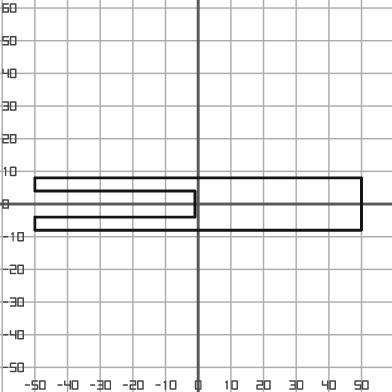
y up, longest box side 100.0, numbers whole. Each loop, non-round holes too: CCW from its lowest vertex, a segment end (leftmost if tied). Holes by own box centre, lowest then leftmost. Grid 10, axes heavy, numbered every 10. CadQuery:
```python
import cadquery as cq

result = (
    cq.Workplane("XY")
    .moveTo(-50.0, -8.0)
    .lineTo(50.0, -8.0)
    .lineTo(50.0, 8.0)
    .lineTo(-50.0, 8.0)
    .lineTo(-50.0, 4.0)
    .lineTo(-1.0, 4.0)
    .lineTo(-1.0, -4.0)
    .lineTo(-50.0, -4.0)
    .close()
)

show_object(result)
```